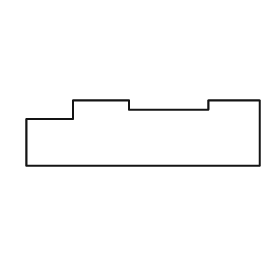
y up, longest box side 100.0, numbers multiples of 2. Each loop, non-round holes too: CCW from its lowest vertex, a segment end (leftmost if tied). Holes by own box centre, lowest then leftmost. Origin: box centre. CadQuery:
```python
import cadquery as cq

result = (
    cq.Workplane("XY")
    .moveTo(-50.0, -14.0)
    .lineTo(50.0, -14.0)
    .lineTo(50.0, 14.0)
    .lineTo(28.0, 14.0)
    .lineTo(28.0, 10.0)
    .lineTo(-6.0, 10.0)
    .lineTo(-6.0, 14.0)
    .lineTo(-30.0, 14.0)
    .lineTo(-30.0, 6.0)
    .lineTo(-50.0, 6.0)
    .close()
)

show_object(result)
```